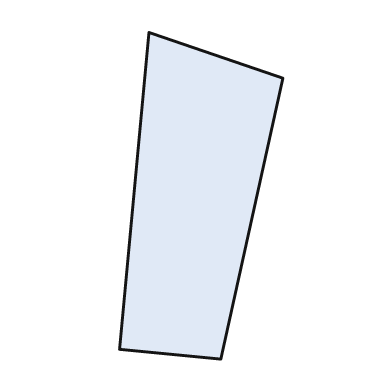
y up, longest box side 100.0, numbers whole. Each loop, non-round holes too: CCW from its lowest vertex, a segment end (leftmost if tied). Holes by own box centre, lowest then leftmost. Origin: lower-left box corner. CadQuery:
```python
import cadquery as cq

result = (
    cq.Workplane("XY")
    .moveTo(31.0, 0.0)
    .lineTo(50.0, 86.0)
    .lineTo(9.0, 100.0)
    .lineTo(0.0, 3.0)
    .close()
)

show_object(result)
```